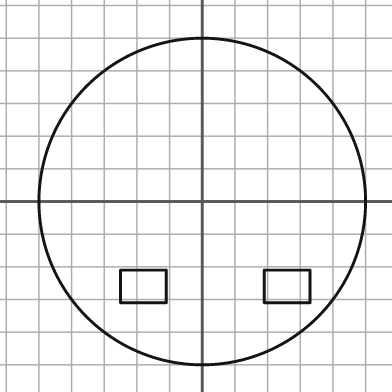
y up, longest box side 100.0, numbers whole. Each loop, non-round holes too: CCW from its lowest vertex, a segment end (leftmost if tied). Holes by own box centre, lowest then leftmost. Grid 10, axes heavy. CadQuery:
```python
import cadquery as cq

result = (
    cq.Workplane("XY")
    .moveTo(0.0, 0.0)
    .circle(50.0)
    .moveTo(-25.0, -31.0)
    .lineTo(-11.0, -31.0)
    .lineTo(-11.0, -21.0)
    .lineTo(-25.0, -21.0)
    .close()
    .moveTo(19.0, -31.0)
    .lineTo(33.0, -31.0)
    .lineTo(33.0, -21.0)
    .lineTo(19.0, -21.0)
    .close()
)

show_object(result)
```